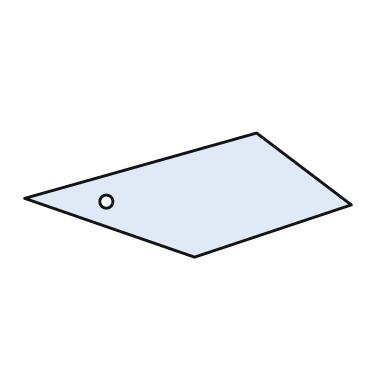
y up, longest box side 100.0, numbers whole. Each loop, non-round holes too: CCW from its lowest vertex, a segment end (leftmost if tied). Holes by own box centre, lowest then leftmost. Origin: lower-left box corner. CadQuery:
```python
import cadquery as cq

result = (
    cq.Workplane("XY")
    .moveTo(52.0, 0.0)
    .lineTo(100.0, 16.0)
    .lineTo(71.0, 38.0)
    .lineTo(0.0, 18.0)
    .close()
    .moveTo(25.0, 17.0)
    .circle(2.0)
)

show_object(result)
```